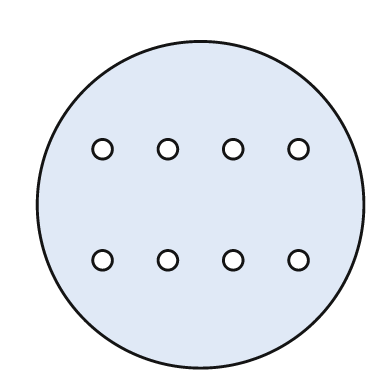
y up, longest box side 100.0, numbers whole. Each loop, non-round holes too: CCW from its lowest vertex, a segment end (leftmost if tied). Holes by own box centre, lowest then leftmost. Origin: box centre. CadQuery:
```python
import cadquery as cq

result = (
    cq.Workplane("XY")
    .moveTo(0.0, 0.0)
    .circle(50.0)
    .moveTo(-30.0, -17.0)
    .circle(3.0)
    .moveTo(-10.0, -17.0)
    .circle(3.0)
    .moveTo(10.0, -17.0)
    .circle(3.0)
    .moveTo(30.0, -17.0)
    .circle(3.0)
    .moveTo(-30.0, 17.0)
    .circle(3.0)
    .moveTo(-10.0, 17.0)
    .circle(3.0)
    .moveTo(10.0, 17.0)
    .circle(3.0)
    .moveTo(30.0, 17.0)
    .circle(3.0)
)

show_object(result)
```